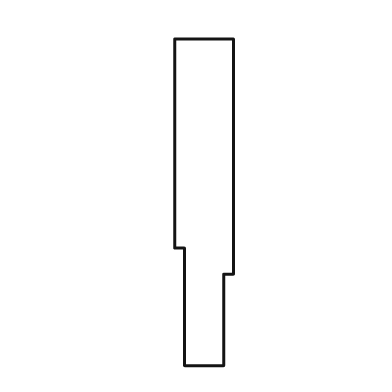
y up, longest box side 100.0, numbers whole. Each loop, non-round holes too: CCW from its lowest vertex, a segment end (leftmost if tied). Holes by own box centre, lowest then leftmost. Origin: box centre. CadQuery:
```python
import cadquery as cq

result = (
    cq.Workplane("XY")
    .moveTo(-6.0, -50.0)
    .lineTo(6.0, -50.0)
    .lineTo(6.0, -22.0)
    .lineTo(9.0, -22.0)
    .lineTo(9.0, 50.0)
    .lineTo(-9.0, 50.0)
    .lineTo(-9.0, -14.0)
    .lineTo(-6.0, -14.0)
    .close()
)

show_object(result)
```